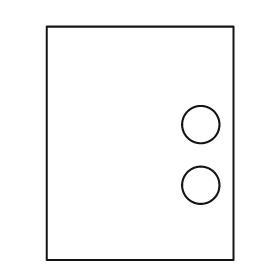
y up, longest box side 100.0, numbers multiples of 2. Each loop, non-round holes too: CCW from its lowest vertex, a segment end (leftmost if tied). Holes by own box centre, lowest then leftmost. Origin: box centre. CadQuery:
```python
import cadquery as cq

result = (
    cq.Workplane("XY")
    .moveTo(-40.0, -50.0)
    .lineTo(40.0, -50.0)
    .lineTo(40.0, 50.0)
    .lineTo(-40.0, 50.0)
    .close()
    .moveTo(26.0, -18.0)
    .circle(8.0)
    .moveTo(26.0, 8.0)
    .circle(8.0)
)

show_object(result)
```